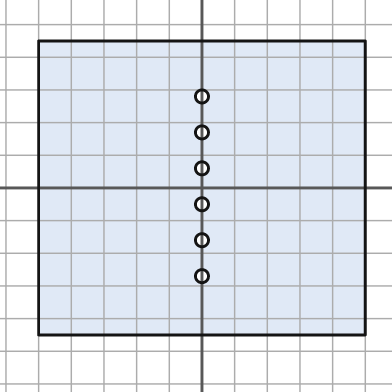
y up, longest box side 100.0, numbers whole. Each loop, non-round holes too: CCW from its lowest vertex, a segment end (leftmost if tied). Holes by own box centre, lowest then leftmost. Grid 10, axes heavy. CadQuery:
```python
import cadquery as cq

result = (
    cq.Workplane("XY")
    .moveTo(-50.0, -45.0)
    .lineTo(50.0, -45.0)
    .lineTo(50.0, 45.0)
    .lineTo(-50.0, 45.0)
    .close()
    .moveTo(0.0, -27.0)
    .circle(2.0)
    .moveTo(0.0, -16.0)
    .circle(2.0)
    .moveTo(0.0, -5.0)
    .circle(2.0)
    .moveTo(0.0, 6.0)
    .circle(2.0)
    .moveTo(0.0, 17.0)
    .circle(2.0)
    .moveTo(0.0, 28.0)
    .circle(2.0)
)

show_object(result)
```